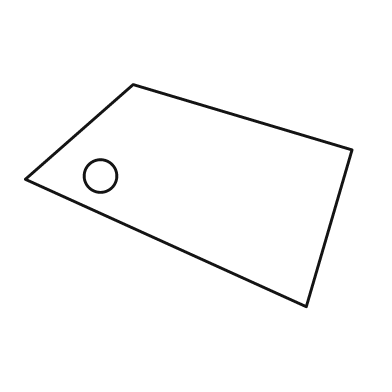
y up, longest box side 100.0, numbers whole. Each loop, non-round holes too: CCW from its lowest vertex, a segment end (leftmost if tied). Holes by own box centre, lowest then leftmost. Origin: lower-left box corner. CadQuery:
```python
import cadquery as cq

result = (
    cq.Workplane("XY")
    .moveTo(86.0, 0.0)
    .lineTo(100.0, 48.0)
    .lineTo(33.0, 68.0)
    .lineTo(0.0, 39.0)
    .close()
    .moveTo(23.0, 40.0)
    .circle(5.0)
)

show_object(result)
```